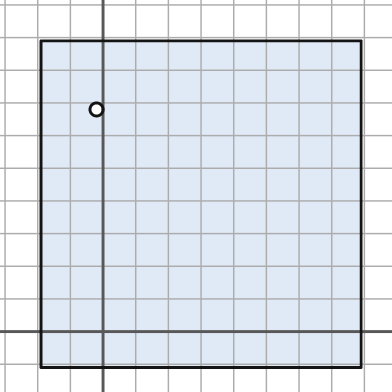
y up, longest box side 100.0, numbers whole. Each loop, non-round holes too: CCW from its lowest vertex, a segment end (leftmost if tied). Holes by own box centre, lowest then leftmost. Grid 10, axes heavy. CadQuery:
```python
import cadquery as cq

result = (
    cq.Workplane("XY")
    .moveTo(-19.0, -11.0)
    .lineTo(79.0, -11.0)
    .lineTo(79.0, 89.0)
    .lineTo(-19.0, 89.0)
    .close()
    .moveTo(-2.0, 68.0)
    .circle(2.0)
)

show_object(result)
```